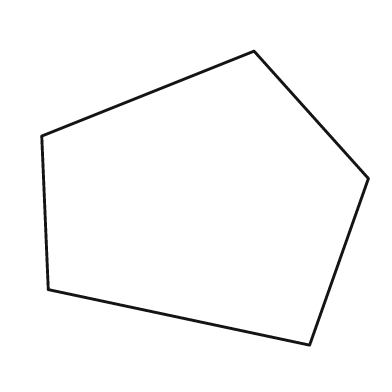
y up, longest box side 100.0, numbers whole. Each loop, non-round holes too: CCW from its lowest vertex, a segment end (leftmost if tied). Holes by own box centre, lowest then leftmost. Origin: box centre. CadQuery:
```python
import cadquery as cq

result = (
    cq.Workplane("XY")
    .moveTo(32.0, -45.0)
    .lineTo(50.0, 6.0)
    .lineTo(15.0, 45.0)
    .lineTo(-50.0, 19.0)
    .lineTo(-48.0, -28.0)
    .close()
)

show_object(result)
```